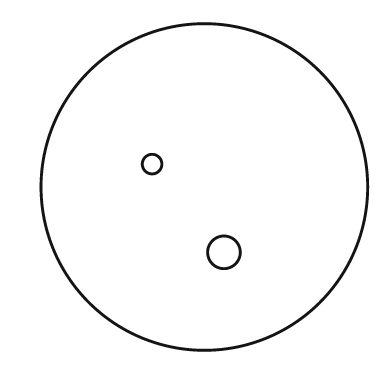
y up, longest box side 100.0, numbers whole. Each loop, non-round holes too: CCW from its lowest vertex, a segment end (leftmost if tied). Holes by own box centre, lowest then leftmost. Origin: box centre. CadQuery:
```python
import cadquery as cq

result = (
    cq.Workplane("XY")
    .moveTo(0.0, 0.0)
    .circle(50.0)
    .moveTo(6.0, -20.0)
    .circle(5.0)
    .moveTo(-16.0, 7.0)
    .circle(3.0)
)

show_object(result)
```